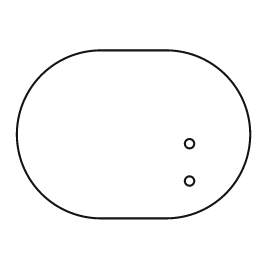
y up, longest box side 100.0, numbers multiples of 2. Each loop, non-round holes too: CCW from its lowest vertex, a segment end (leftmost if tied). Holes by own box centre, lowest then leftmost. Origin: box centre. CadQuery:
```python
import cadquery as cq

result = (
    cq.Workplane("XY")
    .moveTo(-14.0, -36.0)
    .lineTo(14.0, -36.0)
    .threePointArc((50.0, 0.0), (14.0, 36.0))
    .lineTo(-14.0, 36.0)
    .threePointArc((-50.0, 0.0), (-14.0, -36.0))
    .close()
    .moveTo(24.0, -20.0)
    .circle(2.0)
    .moveTo(24.0, -4.0)
    .circle(2.0)
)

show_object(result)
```